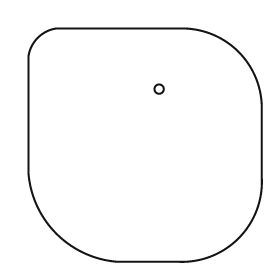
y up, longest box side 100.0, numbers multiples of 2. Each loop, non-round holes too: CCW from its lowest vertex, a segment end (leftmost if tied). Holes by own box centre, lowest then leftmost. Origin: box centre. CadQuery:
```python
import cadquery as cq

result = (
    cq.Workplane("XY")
    .moveTo(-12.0, -50.0)
    .lineTo(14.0, -50.0)
    .threePointArc((40.0, -40.0), (50.0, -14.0))
    .lineTo(50.0, 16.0)
    .threePointArc((40.0, 40.0), (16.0, 50.0))
    .lineTo(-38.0, 50.0)
    .threePointArc((-46.0, 46.0), (-50.0, 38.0))
    .lineTo(-50.0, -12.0)
    .threePointArc((-38.0, -38.0), (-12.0, -50.0))
    .close()
    .moveTo(6.0, 24.0)
    .circle(2.0)
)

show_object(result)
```